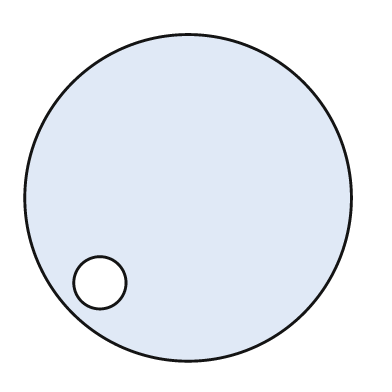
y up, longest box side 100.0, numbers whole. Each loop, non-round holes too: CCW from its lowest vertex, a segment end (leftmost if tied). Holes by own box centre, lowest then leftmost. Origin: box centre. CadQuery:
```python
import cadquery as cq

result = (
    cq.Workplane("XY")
    .moveTo(0.0, 0.0)
    .circle(50.0)
    .moveTo(-27.0, -26.0)
    .circle(8.0)
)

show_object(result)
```